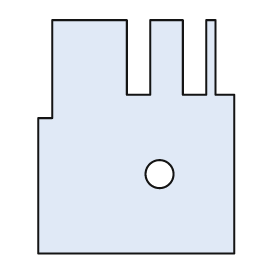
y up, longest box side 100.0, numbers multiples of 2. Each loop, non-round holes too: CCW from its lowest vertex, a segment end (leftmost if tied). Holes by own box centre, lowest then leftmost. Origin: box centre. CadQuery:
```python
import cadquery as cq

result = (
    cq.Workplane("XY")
    .moveTo(-42.0, -50.0)
    .lineTo(42.0, -50.0)
    .lineTo(42.0, 18.0)
    .lineTo(34.0, 18.0)
    .lineTo(34.0, 50.0)
    .lineTo(30.0, 50.0)
    .lineTo(30.0, 18.0)
    .lineTo(20.0, 18.0)
    .lineTo(20.0, 50.0)
    .lineTo(6.0, 50.0)
    .lineTo(6.0, 18.0)
    .lineTo(-4.0, 18.0)
    .lineTo(-4.0, 50.0)
    .lineTo(-36.0, 50.0)
    .lineTo(-36.0, 8.0)
    .lineTo(-42.0, 8.0)
    .close()
    .moveTo(10.0, -16.0)
    .circle(6.0)
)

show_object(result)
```